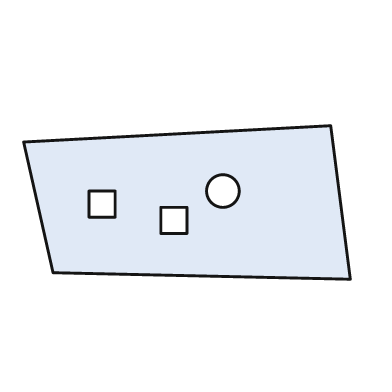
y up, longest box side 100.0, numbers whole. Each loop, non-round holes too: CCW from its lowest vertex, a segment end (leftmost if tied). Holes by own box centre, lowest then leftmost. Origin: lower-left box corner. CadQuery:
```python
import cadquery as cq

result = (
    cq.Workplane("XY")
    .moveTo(100.0, 0.0)
    .lineTo(94.0, 47.0)
    .lineTo(0.0, 42.0)
    .lineTo(9.0, 2.0)
    .close()
    .moveTo(42.0, 14.0)
    .lineTo(50.0, 14.0)
    .lineTo(50.0, 22.0)
    .lineTo(42.0, 22.0)
    .close()
    .moveTo(20.0, 19.0)
    .lineTo(28.0, 19.0)
    .lineTo(28.0, 27.0)
    .lineTo(20.0, 27.0)
    .close()
    .moveTo(61.0, 27.0)
    .circle(5.0)
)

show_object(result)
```